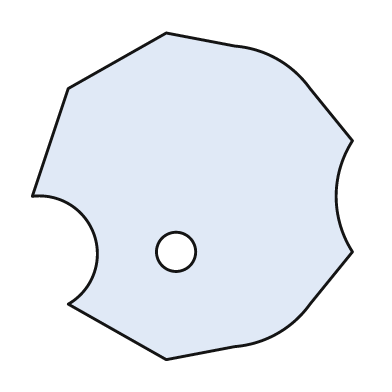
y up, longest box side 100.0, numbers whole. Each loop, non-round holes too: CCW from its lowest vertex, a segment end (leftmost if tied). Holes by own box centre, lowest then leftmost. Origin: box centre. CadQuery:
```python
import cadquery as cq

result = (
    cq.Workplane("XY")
    .moveTo(-8.0, -50.0)
    .lineTo(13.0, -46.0)
    .threePointArc((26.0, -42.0), (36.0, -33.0))
    .lineTo(49.0, -17.0)
    .threePointArc((44.0, 0.0), (49.0, 17.0))
    .lineTo(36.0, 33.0)
    .threePointArc((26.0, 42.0), (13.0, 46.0))
    .lineTo(-8.0, 50.0)
    .lineTo(-38.0, 33.0)
    .lineTo(-49.0, 0.0)
    .threePointArc((-30.0, -12.0), (-38.0, -33.0))
    .close()
    .moveTo(-5.0, -17.0)
    .circle(6.0)
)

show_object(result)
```